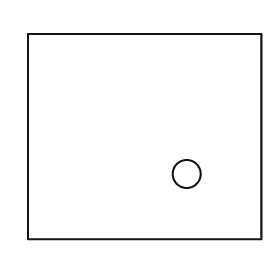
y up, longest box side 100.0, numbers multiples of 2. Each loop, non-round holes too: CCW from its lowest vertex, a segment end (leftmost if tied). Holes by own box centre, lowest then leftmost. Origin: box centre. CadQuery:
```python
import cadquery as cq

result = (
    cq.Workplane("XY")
    .moveTo(-50.0, -44.0)
    .lineTo(50.0, -44.0)
    .lineTo(50.0, 44.0)
    .lineTo(-50.0, 44.0)
    .close()
    .moveTo(18.0, -16.0)
    .circle(6.0)
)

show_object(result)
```